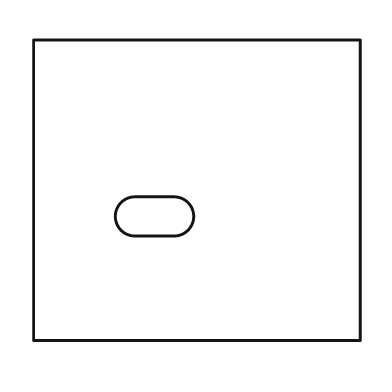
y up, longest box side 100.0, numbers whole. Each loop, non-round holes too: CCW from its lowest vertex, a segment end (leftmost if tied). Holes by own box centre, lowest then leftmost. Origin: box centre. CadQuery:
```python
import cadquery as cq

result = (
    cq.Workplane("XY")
    .moveTo(-50.0, -46.0)
    .lineTo(50.0, -46.0)
    .lineTo(50.0, 46.0)
    .lineTo(-50.0, 46.0)
    .close()
    .moveTo(-19.0, -14.0)
    .lineTo(-7.0, -14.0)
    .threePointArc((-1.0, -8.0), (-7.0, -2.0))
    .lineTo(-19.0, -2.0)
    .threePointArc((-25.0, -8.0), (-19.0, -14.0))
    .close()
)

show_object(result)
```